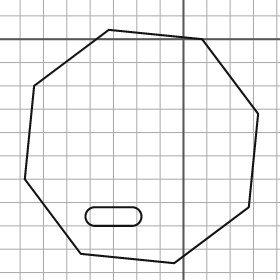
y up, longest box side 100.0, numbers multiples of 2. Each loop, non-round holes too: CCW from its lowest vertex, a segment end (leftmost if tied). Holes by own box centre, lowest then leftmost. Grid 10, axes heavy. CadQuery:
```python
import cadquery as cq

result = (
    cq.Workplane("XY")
    .moveTo(-4.0, -96.0)
    .lineTo(28.0, -72.0)
    .lineTo(32.0, -32.0)
    .lineTo(8.0, 0.0)
    .lineTo(-32.0, 4.0)
    .lineTo(-64.0, -20.0)
    .lineTo(-68.0, -60.0)
    .lineTo(-44.0, -92.0)
    .close()
    .moveTo(-38.0, -80.0)
    .lineTo(-22.0, -80.0)
    .threePointArc((-18.0, -76.0), (-22.0, -72.0))
    .lineTo(-38.0, -72.0)
    .threePointArc((-42.0, -76.0), (-38.0, -80.0))
    .close()
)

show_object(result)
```